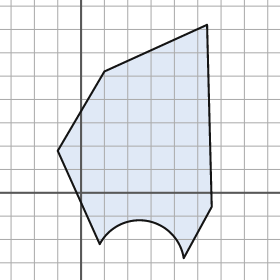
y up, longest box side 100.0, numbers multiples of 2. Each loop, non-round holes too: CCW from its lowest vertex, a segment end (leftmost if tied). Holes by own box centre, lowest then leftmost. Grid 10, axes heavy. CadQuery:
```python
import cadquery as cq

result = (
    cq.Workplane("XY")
    .moveTo(44.0, -28.0)
    .lineTo(56.0, -6.0)
    .lineTo(54.0, 72.0)
    .lineTo(10.0, 52.0)
    .lineTo(-10.0, 18.0)
    .lineTo(8.0, -22.0)
    .threePointArc((28.0, -12.0), (44.0, -28.0))
    .close()
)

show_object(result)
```